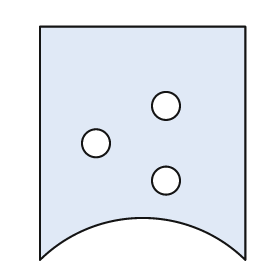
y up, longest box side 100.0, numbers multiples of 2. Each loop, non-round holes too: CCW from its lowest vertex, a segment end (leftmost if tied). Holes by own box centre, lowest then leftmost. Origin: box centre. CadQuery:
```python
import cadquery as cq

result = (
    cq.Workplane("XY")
    .moveTo(-44.0, -50.0)
    .threePointArc((0.0, -32.0), (44.0, -50.0))
    .lineTo(44.0, 50.0)
    .lineTo(-44.0, 50.0)
    .close()
    .moveTo(10.0, -16.0)
    .circle(6.0)
    .moveTo(-20.0, 0.0)
    .circle(6.0)
    .moveTo(10.0, 16.0)
    .circle(6.0)
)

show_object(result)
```